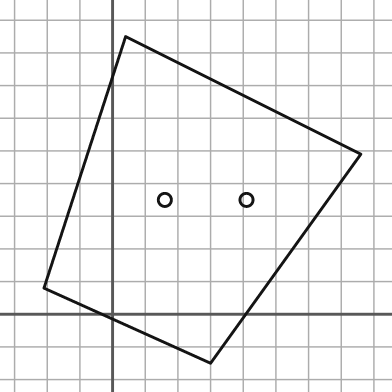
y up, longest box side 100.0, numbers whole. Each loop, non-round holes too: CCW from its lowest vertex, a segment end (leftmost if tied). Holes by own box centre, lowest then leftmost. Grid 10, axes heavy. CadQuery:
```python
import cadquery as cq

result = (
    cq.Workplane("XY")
    .moveTo(30.0, -15.0)
    .lineTo(76.0, 49.0)
    .lineTo(4.0, 85.0)
    .lineTo(-21.0, 8.0)
    .close()
    .moveTo(16.0, 35.0)
    .circle(2.0)
    .moveTo(41.0, 35.0)
    .circle(2.0)
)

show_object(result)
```